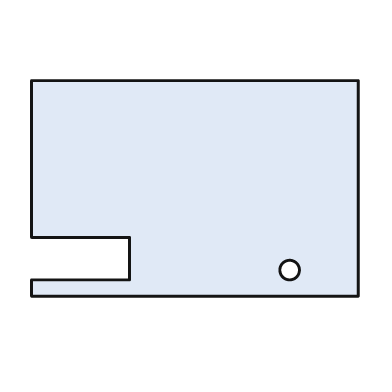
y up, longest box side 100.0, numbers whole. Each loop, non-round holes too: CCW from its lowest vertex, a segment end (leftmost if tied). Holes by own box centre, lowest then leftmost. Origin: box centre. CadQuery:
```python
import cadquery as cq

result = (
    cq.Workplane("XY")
    .moveTo(-50.0, -33.0)
    .lineTo(50.0, -33.0)
    .lineTo(50.0, 33.0)
    .lineTo(-50.0, 33.0)
    .lineTo(-50.0, -15.0)
    .lineTo(-20.0, -15.0)
    .lineTo(-20.0, -28.0)
    .lineTo(-50.0, -28.0)
    .close()
    .moveTo(29.0, -25.0)
    .circle(3.0)
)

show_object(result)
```